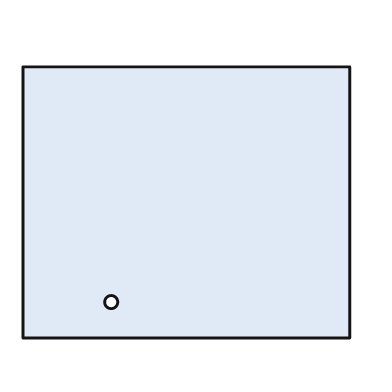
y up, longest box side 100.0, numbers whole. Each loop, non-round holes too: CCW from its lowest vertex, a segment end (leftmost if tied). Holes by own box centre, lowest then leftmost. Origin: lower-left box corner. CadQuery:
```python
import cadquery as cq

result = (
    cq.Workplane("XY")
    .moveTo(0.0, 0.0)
    .lineTo(100.0, 0.0)
    .lineTo(100.0, 83.0)
    .lineTo(0.0, 83.0)
    .close()
    .moveTo(27.0, 11.0)
    .circle(2.0)
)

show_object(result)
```